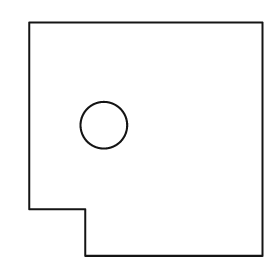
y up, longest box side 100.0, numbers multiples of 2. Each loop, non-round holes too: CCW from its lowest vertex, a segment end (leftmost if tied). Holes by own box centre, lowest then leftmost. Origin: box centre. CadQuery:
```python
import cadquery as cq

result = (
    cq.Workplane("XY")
    .moveTo(-26.0, -50.0)
    .lineTo(50.0, -50.0)
    .lineTo(50.0, 50.0)
    .lineTo(-50.0, 50.0)
    .lineTo(-50.0, -30.0)
    .lineTo(-26.0, -30.0)
    .close()
    .moveTo(-18.0, 6.0)
    .circle(10.0)
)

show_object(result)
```